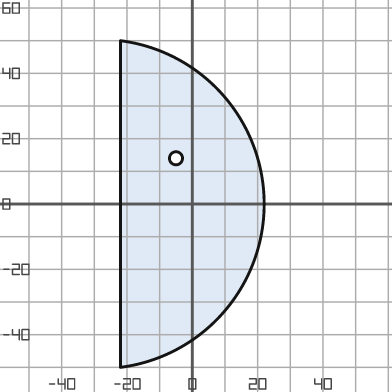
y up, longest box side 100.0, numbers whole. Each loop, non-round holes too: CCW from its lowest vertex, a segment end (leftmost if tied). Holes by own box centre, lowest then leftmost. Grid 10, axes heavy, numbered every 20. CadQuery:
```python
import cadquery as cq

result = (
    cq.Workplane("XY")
    .moveTo(-22.0, -50.0)
    .threePointArc((22.0, 0.0), (-22.0, 50.0))
    .close()
    .moveTo(-5.0, 14.0)
    .circle(2.0)
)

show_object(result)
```